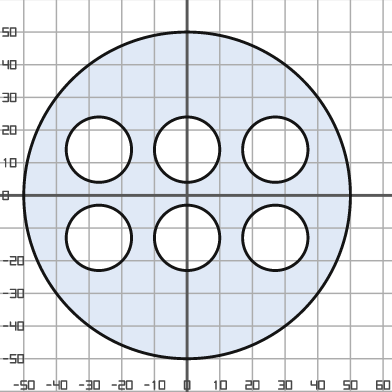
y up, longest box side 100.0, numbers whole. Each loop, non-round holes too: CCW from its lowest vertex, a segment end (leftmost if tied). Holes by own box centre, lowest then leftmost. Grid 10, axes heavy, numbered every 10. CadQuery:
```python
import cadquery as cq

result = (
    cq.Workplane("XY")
    .moveTo(0.0, 0.0)
    .circle(50.0)
    .moveTo(-27.0, -13.0)
    .circle(10.0)
    .moveTo(0.0, -13.0)
    .circle(10.0)
    .moveTo(27.0, -13.0)
    .circle(10.0)
    .moveTo(-27.0, 14.0)
    .circle(10.0)
    .moveTo(0.0, 14.0)
    .circle(10.0)
    .moveTo(27.0, 14.0)
    .circle(10.0)
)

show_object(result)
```